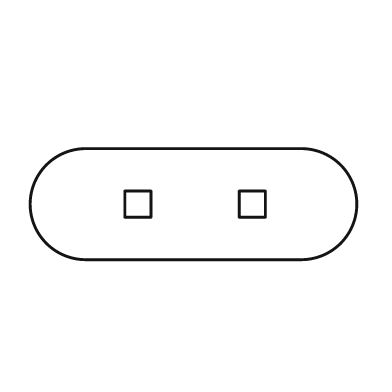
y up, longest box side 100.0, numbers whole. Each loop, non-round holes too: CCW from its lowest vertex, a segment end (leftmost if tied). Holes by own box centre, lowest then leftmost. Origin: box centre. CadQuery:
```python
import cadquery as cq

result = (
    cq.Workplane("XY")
    .moveTo(-33.0, -17.0)
    .lineTo(33.0, -17.0)
    .threePointArc((50.0, 0.0), (33.0, 17.0))
    .lineTo(-33.0, 17.0)
    .threePointArc((-50.0, 0.0), (-33.0, -17.0))
    .close()
    .moveTo(-21.0, -4.0)
    .lineTo(-13.0, -4.0)
    .lineTo(-13.0, 4.0)
    .lineTo(-21.0, 4.0)
    .close()
    .moveTo(14.0, -4.0)
    .lineTo(22.0, -4.0)
    .lineTo(22.0, 4.0)
    .lineTo(14.0, 4.0)
    .close()
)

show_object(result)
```